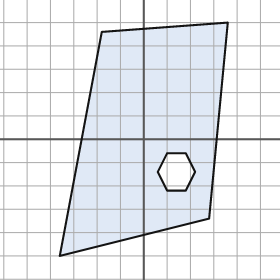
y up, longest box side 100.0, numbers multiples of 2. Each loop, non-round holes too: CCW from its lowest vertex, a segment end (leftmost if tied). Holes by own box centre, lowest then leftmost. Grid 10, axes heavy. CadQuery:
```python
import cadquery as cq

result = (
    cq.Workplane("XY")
    .moveTo(-36.0, -50.0)
    .lineTo(28.0, -34.0)
    .lineTo(36.0, 50.0)
    .lineTo(-18.0, 46.0)
    .close()
    .moveTo(10.0, -22.0)
    .lineTo(18.0, -22.0)
    .lineTo(22.0, -14.0)
    .lineTo(18.0, -6.0)
    .lineTo(10.0, -6.0)
    .lineTo(6.0, -14.0)
    .close()
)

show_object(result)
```